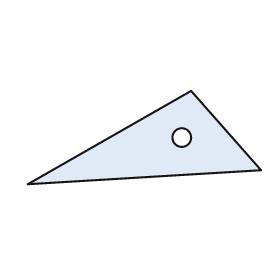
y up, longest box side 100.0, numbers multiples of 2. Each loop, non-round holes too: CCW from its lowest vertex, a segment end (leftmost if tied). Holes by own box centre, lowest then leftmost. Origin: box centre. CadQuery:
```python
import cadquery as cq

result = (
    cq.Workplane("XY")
    .moveTo(-50.0, -20.0)
    .lineTo(50.0, -14.0)
    .lineTo(20.0, 20.0)
    .close()
    .moveTo(16.0, 0.0)
    .circle(4.0)
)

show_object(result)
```